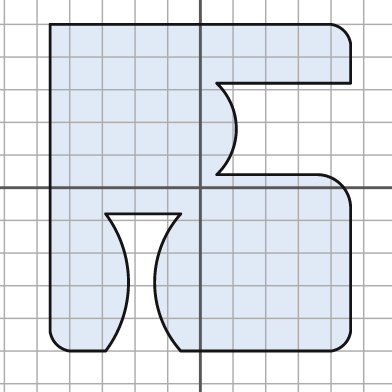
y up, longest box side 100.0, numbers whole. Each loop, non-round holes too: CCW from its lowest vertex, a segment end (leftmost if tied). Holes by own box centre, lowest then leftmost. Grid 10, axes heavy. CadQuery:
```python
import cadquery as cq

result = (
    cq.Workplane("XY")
    .moveTo(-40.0, -50.0)
    .lineTo(-29.0, -50.0)
    .threePointArc((-22.0, -29.0), (-29.0, -8.0))
    .lineTo(-6.0, -8.0)
    .threePointArc((-14.0, -29.0), (-6.0, -50.0))
    .lineTo(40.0, -50.0)
    .threePointArc((44.0, -48.0), (46.0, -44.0))
    .lineTo(46.0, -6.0)
    .threePointArc((43.0, 1.0), (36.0, 4.0))
    .lineTo(5.0, 4.0)
    .threePointArc((11.0, 18.0), (5.0, 32.0))
    .lineTo(46.0, 32.0)
    .lineTo(46.0, 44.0)
    .threePointArc((44.0, 48.0), (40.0, 50.0))
    .lineTo(-46.0, 50.0)
    .lineTo(-46.0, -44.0)
    .threePointArc((-44.0, -48.0), (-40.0, -50.0))
    .close()
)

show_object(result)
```